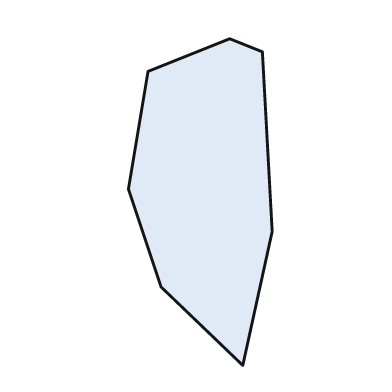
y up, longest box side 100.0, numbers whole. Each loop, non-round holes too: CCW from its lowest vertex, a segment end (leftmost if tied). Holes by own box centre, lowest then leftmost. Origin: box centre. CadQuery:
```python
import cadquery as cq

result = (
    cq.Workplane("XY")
    .moveTo(13.0, -50.0)
    .lineTo(22.0, -9.0)
    .lineTo(19.0, 46.0)
    .lineTo(9.0, 50.0)
    .lineTo(-16.0, 40.0)
    .lineTo(-22.0, 4.0)
    .lineTo(-12.0, -26.0)
    .close()
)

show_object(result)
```